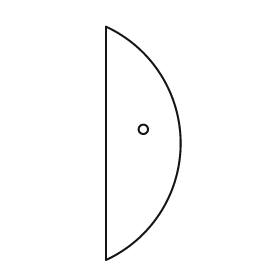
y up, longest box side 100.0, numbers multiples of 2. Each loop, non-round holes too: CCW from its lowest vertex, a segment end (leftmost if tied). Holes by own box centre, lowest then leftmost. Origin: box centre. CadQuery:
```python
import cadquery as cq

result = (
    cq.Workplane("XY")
    .moveTo(-16.0, -50.0)
    .threePointArc((16.0, 0.0), (-16.0, 50.0))
    .close()
    .moveTo(0.0, 6.0)
    .circle(2.0)
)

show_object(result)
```